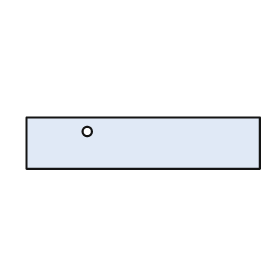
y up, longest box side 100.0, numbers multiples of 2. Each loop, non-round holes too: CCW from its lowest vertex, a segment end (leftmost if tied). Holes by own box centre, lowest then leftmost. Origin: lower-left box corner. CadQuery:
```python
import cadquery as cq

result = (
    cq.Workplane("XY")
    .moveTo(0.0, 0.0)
    .lineTo(100.0, 0.0)
    .lineTo(100.0, 22.0)
    .lineTo(0.0, 22.0)
    .close()
    .moveTo(26.0, 16.0)
    .circle(2.0)
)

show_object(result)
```